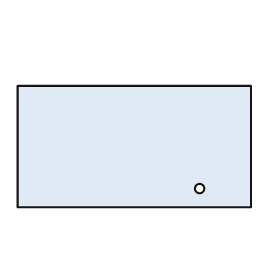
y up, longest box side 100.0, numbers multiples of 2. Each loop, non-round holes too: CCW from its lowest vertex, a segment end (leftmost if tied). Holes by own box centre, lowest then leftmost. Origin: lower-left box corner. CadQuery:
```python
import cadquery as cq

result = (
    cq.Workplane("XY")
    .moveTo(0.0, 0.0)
    .lineTo(100.0, 0.0)
    .lineTo(100.0, 52.0)
    .lineTo(0.0, 52.0)
    .close()
    .moveTo(78.0, 8.0)
    .circle(2.0)
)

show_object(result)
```